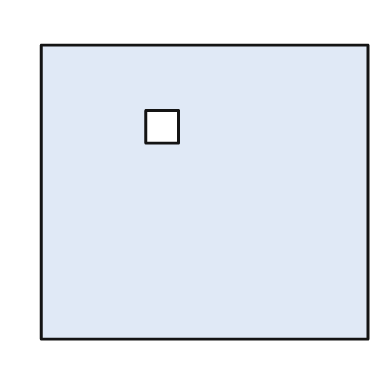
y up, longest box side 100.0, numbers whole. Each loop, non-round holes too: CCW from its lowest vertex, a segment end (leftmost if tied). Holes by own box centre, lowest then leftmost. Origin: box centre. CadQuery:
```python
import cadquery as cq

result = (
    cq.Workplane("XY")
    .moveTo(-50.0, -45.0)
    .lineTo(50.0, -45.0)
    .lineTo(50.0, 45.0)
    .lineTo(-50.0, 45.0)
    .close()
    .moveTo(-18.0, 15.0)
    .lineTo(-8.0, 15.0)
    .lineTo(-8.0, 25.0)
    .lineTo(-18.0, 25.0)
    .close()
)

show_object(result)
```